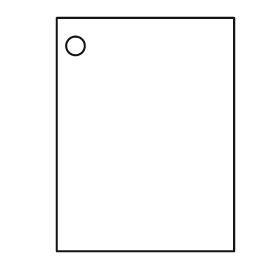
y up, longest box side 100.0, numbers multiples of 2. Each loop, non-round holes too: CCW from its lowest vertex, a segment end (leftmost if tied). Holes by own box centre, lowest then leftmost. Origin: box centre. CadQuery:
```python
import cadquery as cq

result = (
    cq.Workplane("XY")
    .moveTo(-38.0, -50.0)
    .lineTo(38.0, -50.0)
    .lineTo(38.0, 50.0)
    .lineTo(-38.0, 50.0)
    .close()
    .moveTo(-30.0, 38.0)
    .circle(4.0)
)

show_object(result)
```